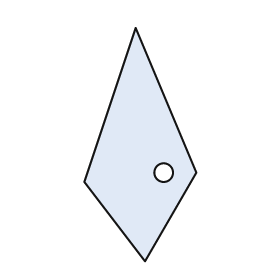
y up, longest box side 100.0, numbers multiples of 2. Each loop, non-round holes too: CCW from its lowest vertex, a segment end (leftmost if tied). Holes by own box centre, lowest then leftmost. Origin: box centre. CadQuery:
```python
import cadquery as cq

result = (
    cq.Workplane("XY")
    .moveTo(2.0, -50.0)
    .lineTo(24.0, -12.0)
    .lineTo(-2.0, 50.0)
    .lineTo(-24.0, -16.0)
    .close()
    .moveTo(10.0, -12.0)
    .circle(4.0)
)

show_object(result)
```